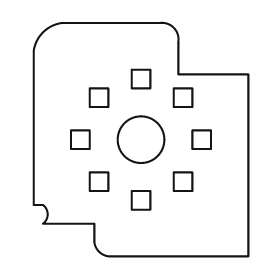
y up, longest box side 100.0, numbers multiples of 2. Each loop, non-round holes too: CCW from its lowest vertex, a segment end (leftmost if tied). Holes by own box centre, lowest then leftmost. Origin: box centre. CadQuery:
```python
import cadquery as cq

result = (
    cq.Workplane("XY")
    .moveTo(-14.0, -50.0)
    .lineTo(46.0, -50.0)
    .lineTo(46.0, 28.0)
    .lineTo(16.0, 28.0)
    .lineTo(16.0, 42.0)
    .threePointArc((14.0, 48.0), (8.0, 50.0))
    .lineTo(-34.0, 50.0)
    .threePointArc((-42.0, 46.0), (-46.0, 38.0))
    .lineTo(-46.0, -28.0)
    .lineTo(-42.0, -28.0)
    .threePointArc((-40.0, -32.0), (-42.0, -36.0))
    .lineTo(-20.0, -36.0)
    .lineTo(-20.0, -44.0)
    .threePointArc((-18.0, -48.0), (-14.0, -50.0))
    .close()
    .moveTo(-4.0, -30.0)
    .lineTo(4.0, -30.0)
    .lineTo(4.0, -22.0)
    .lineTo(-4.0, -22.0)
    .close()
    .moveTo(-22.0, -22.0)
    .lineTo(-14.0, -22.0)
    .lineTo(-14.0, -14.0)
    .lineTo(-22.0, -14.0)
    .close()
    .moveTo(14.0, -22.0)
    .lineTo(22.0, -22.0)
    .lineTo(22.0, -14.0)
    .lineTo(14.0, -14.0)
    .close()
    .moveTo(-30.0, -4.0)
    .lineTo(-22.0, -4.0)
    .lineTo(-22.0, 4.0)
    .lineTo(-30.0, 4.0)
    .close()
    .moveTo(0.0, 0.0)
    .circle(10.0)
    .moveTo(22.0, -4.0)
    .lineTo(30.0, -4.0)
    .lineTo(30.0, 4.0)
    .lineTo(22.0, 4.0)
    .close()
    .moveTo(-22.0, 14.0)
    .lineTo(-14.0, 14.0)
    .lineTo(-14.0, 22.0)
    .lineTo(-22.0, 22.0)
    .close()
    .moveTo(14.0, 14.0)
    .lineTo(22.0, 14.0)
    .lineTo(22.0, 22.0)
    .lineTo(14.0, 22.0)
    .close()
    .moveTo(-4.0, 22.0)
    .lineTo(4.0, 22.0)
    .lineTo(4.0, 30.0)
    .lineTo(-4.0, 30.0)
    .close()
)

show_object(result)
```